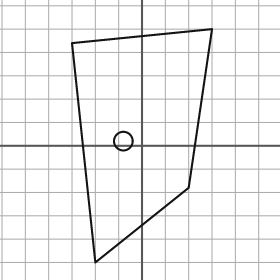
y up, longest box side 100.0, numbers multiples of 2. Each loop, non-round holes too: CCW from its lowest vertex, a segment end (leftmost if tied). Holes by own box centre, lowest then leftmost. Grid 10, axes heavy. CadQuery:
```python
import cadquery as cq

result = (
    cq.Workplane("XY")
    .moveTo(-20.0, -50.0)
    .lineTo(20.0, -18.0)
    .lineTo(30.0, 50.0)
    .lineTo(-30.0, 44.0)
    .close()
    .moveTo(-8.0, 2.0)
    .circle(4.0)
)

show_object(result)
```